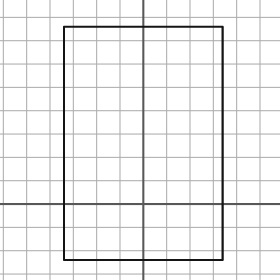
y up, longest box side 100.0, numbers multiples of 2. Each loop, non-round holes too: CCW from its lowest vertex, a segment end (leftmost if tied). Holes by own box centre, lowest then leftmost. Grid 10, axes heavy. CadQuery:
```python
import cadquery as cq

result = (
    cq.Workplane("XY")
    .moveTo(-34.0, -24.0)
    .lineTo(34.0, -24.0)
    .lineTo(34.0, 76.0)
    .lineTo(-34.0, 76.0)
    .close()
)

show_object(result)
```